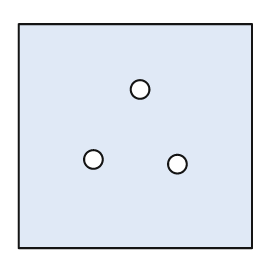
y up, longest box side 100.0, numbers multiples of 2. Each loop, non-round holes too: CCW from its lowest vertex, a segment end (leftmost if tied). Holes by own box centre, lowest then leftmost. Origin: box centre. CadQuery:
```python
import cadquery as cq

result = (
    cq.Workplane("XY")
    .moveTo(-50.0, -48.0)
    .lineTo(50.0, -48.0)
    .lineTo(50.0, 48.0)
    .lineTo(-50.0, 48.0)
    .close()
    .moveTo(18.0, -12.0)
    .circle(4.0)
    .moveTo(-18.0, -10.0)
    .circle(4.0)
    .moveTo(2.0, 20.0)
    .circle(4.0)
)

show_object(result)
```